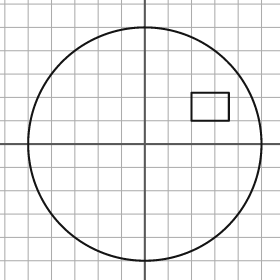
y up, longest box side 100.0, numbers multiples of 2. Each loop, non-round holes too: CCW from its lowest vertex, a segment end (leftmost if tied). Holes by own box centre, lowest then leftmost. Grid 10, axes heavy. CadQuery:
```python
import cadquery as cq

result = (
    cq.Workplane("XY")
    .moveTo(0.0, 0.0)
    .circle(50.0)
    .moveTo(20.0, 10.0)
    .lineTo(36.0, 10.0)
    .lineTo(36.0, 22.0)
    .lineTo(20.0, 22.0)
    .close()
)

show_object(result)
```